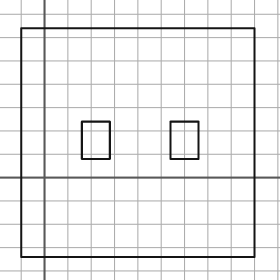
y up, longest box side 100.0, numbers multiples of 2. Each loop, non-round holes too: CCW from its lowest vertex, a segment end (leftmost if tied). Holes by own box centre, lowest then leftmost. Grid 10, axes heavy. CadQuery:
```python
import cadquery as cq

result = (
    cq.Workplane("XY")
    .moveTo(-10.0, -34.0)
    .lineTo(90.0, -34.0)
    .lineTo(90.0, 64.0)
    .lineTo(-10.0, 64.0)
    .close()
    .moveTo(16.0, 8.0)
    .lineTo(28.0, 8.0)
    .lineTo(28.0, 24.0)
    .lineTo(16.0, 24.0)
    .close()
    .moveTo(54.0, 8.0)
    .lineTo(66.0, 8.0)
    .lineTo(66.0, 24.0)
    .lineTo(54.0, 24.0)
    .close()
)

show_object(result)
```